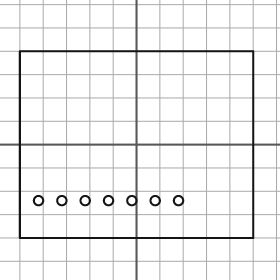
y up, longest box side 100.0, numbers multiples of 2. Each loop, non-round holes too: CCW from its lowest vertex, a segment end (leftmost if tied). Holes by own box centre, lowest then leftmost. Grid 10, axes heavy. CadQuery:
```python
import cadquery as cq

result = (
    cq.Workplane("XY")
    .moveTo(-50.0, -40.0)
    .lineTo(50.0, -40.0)
    .lineTo(50.0, 40.0)
    .lineTo(-50.0, 40.0)
    .close()
    .moveTo(-42.0, -24.0)
    .circle(2.0)
    .moveTo(-32.0, -24.0)
    .circle(2.0)
    .moveTo(-22.0, -24.0)
    .circle(2.0)
    .moveTo(-12.0, -24.0)
    .circle(2.0)
    .moveTo(-2.0, -24.0)
    .circle(2.0)
    .moveTo(8.0, -24.0)
    .circle(2.0)
    .moveTo(18.0, -24.0)
    .circle(2.0)
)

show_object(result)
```